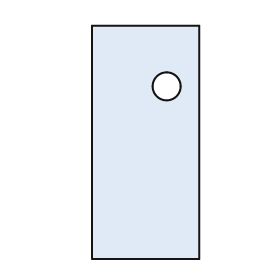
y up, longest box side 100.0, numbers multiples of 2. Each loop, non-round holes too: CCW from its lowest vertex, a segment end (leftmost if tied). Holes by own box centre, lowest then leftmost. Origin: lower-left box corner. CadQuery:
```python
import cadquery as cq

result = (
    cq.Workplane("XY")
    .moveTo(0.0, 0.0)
    .lineTo(46.0, 0.0)
    .lineTo(46.0, 100.0)
    .lineTo(0.0, 100.0)
    .close()
    .moveTo(32.0, 74.0)
    .circle(6.0)
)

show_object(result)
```